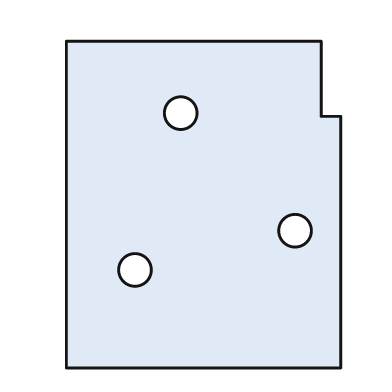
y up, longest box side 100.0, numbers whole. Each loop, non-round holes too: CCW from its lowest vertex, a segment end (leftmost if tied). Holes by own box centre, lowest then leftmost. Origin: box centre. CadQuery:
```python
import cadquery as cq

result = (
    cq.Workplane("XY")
    .moveTo(-42.0, -50.0)
    .lineTo(42.0, -50.0)
    .lineTo(42.0, 27.0)
    .lineTo(36.0, 27.0)
    .lineTo(36.0, 50.0)
    .lineTo(-42.0, 50.0)
    .close()
    .moveTo(-21.0, -20.0)
    .circle(5.0)
    .moveTo(28.0, -8.0)
    .circle(5.0)
    .moveTo(-7.0, 28.0)
    .circle(5.0)
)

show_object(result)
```